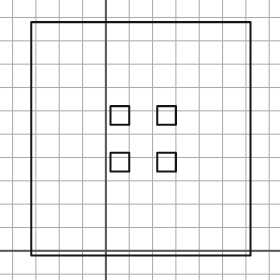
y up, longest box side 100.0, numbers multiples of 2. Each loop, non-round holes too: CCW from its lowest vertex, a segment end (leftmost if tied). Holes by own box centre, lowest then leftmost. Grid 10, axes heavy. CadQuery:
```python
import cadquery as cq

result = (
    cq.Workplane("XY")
    .moveTo(-32.0, -2.0)
    .lineTo(62.0, -2.0)
    .lineTo(62.0, 98.0)
    .lineTo(-32.0, 98.0)
    .close()
    .moveTo(2.0, 34.0)
    .lineTo(10.0, 34.0)
    .lineTo(10.0, 42.0)
    .lineTo(2.0, 42.0)
    .close()
    .moveTo(22.0, 34.0)
    .lineTo(30.0, 34.0)
    .lineTo(30.0, 42.0)
    .lineTo(22.0, 42.0)
    .close()
    .moveTo(2.0, 54.0)
    .lineTo(10.0, 54.0)
    .lineTo(10.0, 62.0)
    .lineTo(2.0, 62.0)
    .close()
    .moveTo(22.0, 54.0)
    .lineTo(30.0, 54.0)
    .lineTo(30.0, 62.0)
    .lineTo(22.0, 62.0)
    .close()
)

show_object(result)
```